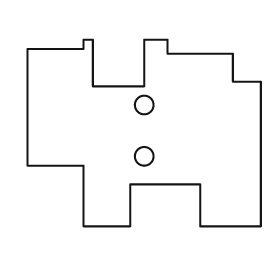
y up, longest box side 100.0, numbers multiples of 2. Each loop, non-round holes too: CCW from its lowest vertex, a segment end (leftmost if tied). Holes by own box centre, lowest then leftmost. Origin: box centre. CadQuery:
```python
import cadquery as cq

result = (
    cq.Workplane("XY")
    .moveTo(-26.0, -40.0)
    .lineTo(-6.0, -40.0)
    .lineTo(-6.0, -22.0)
    .lineTo(24.0, -22.0)
    .lineTo(24.0, -40.0)
    .lineTo(50.0, -40.0)
    .lineTo(50.0, 22.0)
    .lineTo(38.0, 22.0)
    .lineTo(38.0, 34.0)
    .lineTo(10.0, 34.0)
    .lineTo(10.0, 40.0)
    .lineTo(0.0, 40.0)
    .lineTo(0.0, 20.0)
    .lineTo(-22.0, 20.0)
    .lineTo(-22.0, 40.0)
    .lineTo(-26.0, 40.0)
    .lineTo(-26.0, 36.0)
    .lineTo(-50.0, 36.0)
    .lineTo(-50.0, -14.0)
    .lineTo(-26.0, -14.0)
    .close()
    .moveTo(0.0, -10.0)
    .circle(4.0)
    .moveTo(0.0, 12.0)
    .circle(4.0)
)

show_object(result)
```